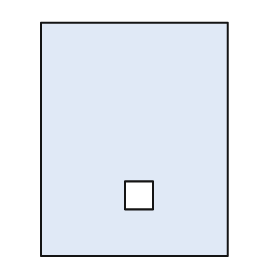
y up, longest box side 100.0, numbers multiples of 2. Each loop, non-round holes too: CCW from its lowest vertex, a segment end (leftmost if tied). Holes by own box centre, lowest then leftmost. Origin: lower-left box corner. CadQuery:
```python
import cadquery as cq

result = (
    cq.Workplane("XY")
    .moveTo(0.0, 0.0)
    .lineTo(80.0, 0.0)
    .lineTo(80.0, 100.0)
    .lineTo(0.0, 100.0)
    .close()
    .moveTo(36.0, 20.0)
    .lineTo(48.0, 20.0)
    .lineTo(48.0, 32.0)
    .lineTo(36.0, 32.0)
    .close()
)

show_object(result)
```